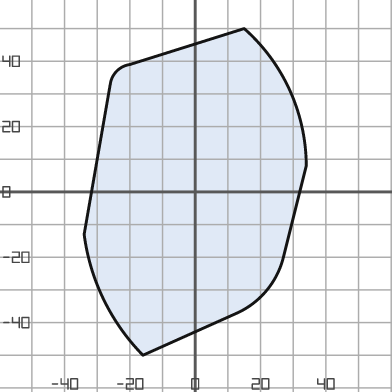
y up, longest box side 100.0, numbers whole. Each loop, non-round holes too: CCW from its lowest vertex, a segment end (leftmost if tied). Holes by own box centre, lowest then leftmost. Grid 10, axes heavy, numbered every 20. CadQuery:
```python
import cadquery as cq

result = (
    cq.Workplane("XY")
    .moveTo(-16.0, -50.0)
    .lineTo(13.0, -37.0)
    .threePointArc((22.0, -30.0), (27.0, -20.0))
    .lineTo(34.0, 8.0)
    .threePointArc((29.0, 31.0), (15.0, 50.0))
    .lineTo(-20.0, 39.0)
    .threePointArc((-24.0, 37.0), (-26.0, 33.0))
    .lineTo(-34.0, -13.0)
    .threePointArc((-28.0, -33.0), (-16.0, -50.0))
    .close()
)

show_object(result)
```